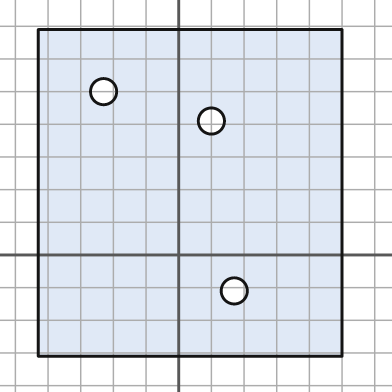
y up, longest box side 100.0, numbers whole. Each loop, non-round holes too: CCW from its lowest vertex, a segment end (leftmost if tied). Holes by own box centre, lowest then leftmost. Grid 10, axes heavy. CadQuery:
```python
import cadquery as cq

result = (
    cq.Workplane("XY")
    .moveTo(-43.0, -31.0)
    .lineTo(50.0, -31.0)
    .lineTo(50.0, 69.0)
    .lineTo(-43.0, 69.0)
    .close()
    .moveTo(17.0, -11.0)
    .circle(4.0)
    .moveTo(10.0, 41.0)
    .circle(4.0)
    .moveTo(-23.0, 50.0)
    .circle(4.0)
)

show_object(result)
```